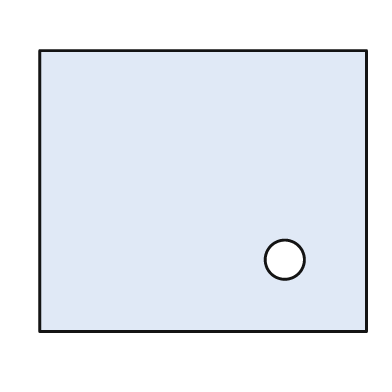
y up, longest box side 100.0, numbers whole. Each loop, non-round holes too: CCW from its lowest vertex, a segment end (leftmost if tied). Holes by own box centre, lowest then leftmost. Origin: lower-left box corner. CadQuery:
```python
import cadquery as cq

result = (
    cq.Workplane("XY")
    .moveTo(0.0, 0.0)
    .lineTo(100.0, 0.0)
    .lineTo(100.0, 86.0)
    .lineTo(0.0, 86.0)
    .close()
    .moveTo(75.0, 22.0)
    .circle(6.0)
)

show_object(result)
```